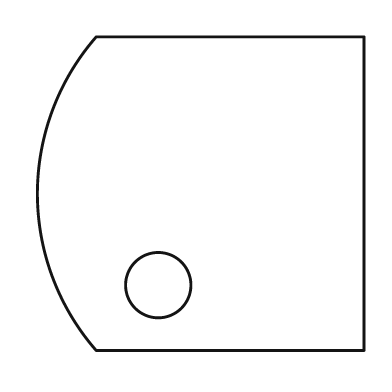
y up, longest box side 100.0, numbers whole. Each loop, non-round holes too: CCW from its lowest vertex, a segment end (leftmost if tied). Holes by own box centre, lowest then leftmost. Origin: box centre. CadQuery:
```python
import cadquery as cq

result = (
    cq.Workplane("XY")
    .moveTo(-32.0, -48.0)
    .lineTo(50.0, -48.0)
    .lineTo(50.0, 48.0)
    .lineTo(-32.0, 48.0)
    .threePointArc((-50.0, 0.0), (-32.0, -48.0))
    .close()
    .moveTo(-13.0, -28.0)
    .circle(10.0)
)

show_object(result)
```